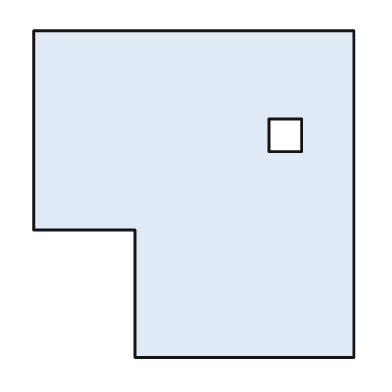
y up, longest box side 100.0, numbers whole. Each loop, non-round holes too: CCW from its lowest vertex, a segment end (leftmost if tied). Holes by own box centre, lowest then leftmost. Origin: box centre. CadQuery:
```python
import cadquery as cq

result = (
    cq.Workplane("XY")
    .moveTo(-18.0, -50.0)
    .lineTo(49.0, -50.0)
    .lineTo(49.0, 50.0)
    .lineTo(-49.0, 50.0)
    .lineTo(-49.0, -11.0)
    .lineTo(-18.0, -11.0)
    .close()
    .moveTo(23.0, 13.0)
    .lineTo(33.0, 13.0)
    .lineTo(33.0, 23.0)
    .lineTo(23.0, 23.0)
    .close()
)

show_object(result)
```